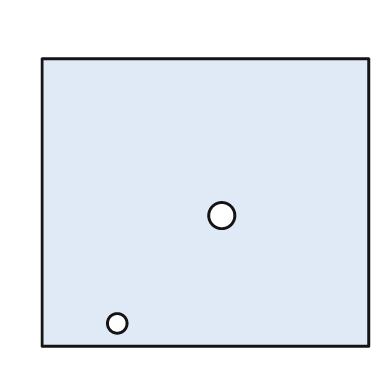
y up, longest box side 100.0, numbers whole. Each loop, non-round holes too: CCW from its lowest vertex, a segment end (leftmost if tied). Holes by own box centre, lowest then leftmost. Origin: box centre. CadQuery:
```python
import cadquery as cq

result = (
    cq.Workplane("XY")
    .moveTo(-50.0, -44.0)
    .lineTo(50.0, -44.0)
    .lineTo(50.0, 44.0)
    .lineTo(-50.0, 44.0)
    .close()
    .moveTo(-27.0, -37.0)
    .circle(3.0)
    .moveTo(5.0, -4.0)
    .circle(4.0)
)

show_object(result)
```